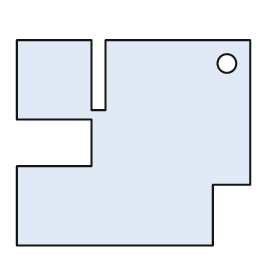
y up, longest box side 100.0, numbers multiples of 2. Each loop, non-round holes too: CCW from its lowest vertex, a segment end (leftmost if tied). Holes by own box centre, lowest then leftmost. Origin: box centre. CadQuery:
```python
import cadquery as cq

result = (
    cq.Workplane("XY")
    .moveTo(-50.0, -44.0)
    .lineTo(34.0, -44.0)
    .lineTo(34.0, -18.0)
    .lineTo(50.0, -18.0)
    .lineTo(50.0, 44.0)
    .lineTo(-12.0, 44.0)
    .lineTo(-12.0, 14.0)
    .lineTo(-18.0, 14.0)
    .lineTo(-18.0, 44.0)
    .lineTo(-50.0, 44.0)
    .lineTo(-50.0, 10.0)
    .lineTo(-18.0, 10.0)
    .lineTo(-18.0, -10.0)
    .lineTo(-50.0, -10.0)
    .close()
    .moveTo(40.0, 34.0)
    .circle(4.0)
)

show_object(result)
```